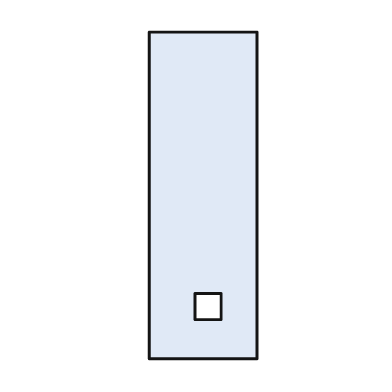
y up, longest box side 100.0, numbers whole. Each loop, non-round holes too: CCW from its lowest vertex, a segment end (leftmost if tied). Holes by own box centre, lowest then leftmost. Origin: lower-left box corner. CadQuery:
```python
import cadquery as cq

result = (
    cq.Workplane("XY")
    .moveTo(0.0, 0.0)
    .lineTo(33.0, 0.0)
    .lineTo(33.0, 100.0)
    .lineTo(0.0, 100.0)
    .close()
    .moveTo(14.0, 12.0)
    .lineTo(22.0, 12.0)
    .lineTo(22.0, 20.0)
    .lineTo(14.0, 20.0)
    .close()
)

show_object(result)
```